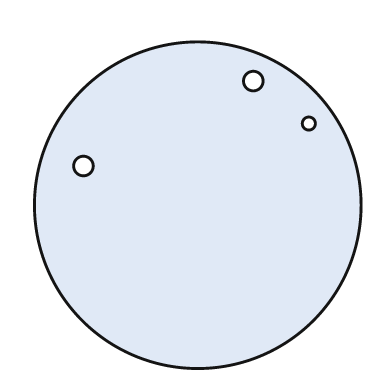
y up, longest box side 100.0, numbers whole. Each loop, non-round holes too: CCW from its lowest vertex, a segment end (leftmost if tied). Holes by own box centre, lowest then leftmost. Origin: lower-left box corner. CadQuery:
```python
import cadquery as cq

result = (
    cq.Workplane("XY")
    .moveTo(50.0, 50.0)
    .circle(50.0)
    .moveTo(15.0, 62.0)
    .circle(3.0)
    .moveTo(84.0, 75.0)
    .circle(2.0)
    .moveTo(67.0, 88.0)
    .circle(3.0)
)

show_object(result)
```